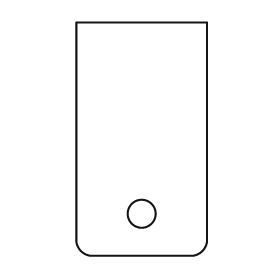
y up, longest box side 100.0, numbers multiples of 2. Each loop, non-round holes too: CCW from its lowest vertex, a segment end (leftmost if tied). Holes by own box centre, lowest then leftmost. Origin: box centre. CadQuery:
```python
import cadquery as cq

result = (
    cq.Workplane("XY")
    .moveTo(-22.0, -50.0)
    .lineTo(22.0, -50.0)
    .threePointArc((26.0, -48.0), (28.0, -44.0))
    .lineTo(28.0, 50.0)
    .lineTo(-28.0, 50.0)
    .lineTo(-28.0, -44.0)
    .threePointArc((-26.0, -48.0), (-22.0, -50.0))
    .close()
    .moveTo(0.0, -32.0)
    .circle(6.0)
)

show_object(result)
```